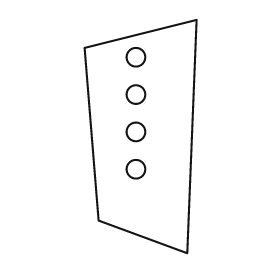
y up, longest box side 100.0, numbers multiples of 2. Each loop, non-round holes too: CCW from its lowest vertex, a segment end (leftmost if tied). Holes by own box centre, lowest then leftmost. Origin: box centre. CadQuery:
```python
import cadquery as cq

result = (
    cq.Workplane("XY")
    .moveTo(20.0, -50.0)
    .lineTo(24.0, 50.0)
    .lineTo(-24.0, 38.0)
    .lineTo(-18.0, -36.0)
    .close()
    .moveTo(-2.0, -14.0)
    .circle(4.0)
    .moveTo(-2.0, 2.0)
    .circle(4.0)
    .moveTo(-2.0, 18.0)
    .circle(4.0)
    .moveTo(-2.0, 34.0)
    .circle(4.0)
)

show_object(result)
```